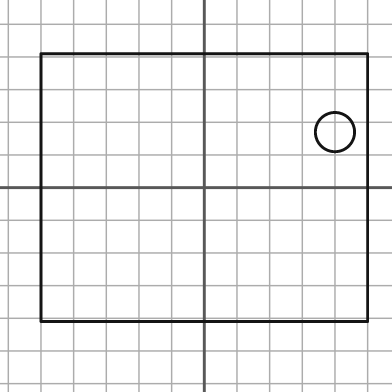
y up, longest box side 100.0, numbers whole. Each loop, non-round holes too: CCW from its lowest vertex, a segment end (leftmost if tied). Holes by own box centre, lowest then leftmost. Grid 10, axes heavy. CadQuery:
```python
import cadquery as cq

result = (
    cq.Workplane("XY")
    .moveTo(-50.0, -41.0)
    .lineTo(50.0, -41.0)
    .lineTo(50.0, 41.0)
    .lineTo(-50.0, 41.0)
    .close()
    .moveTo(40.0, 17.0)
    .circle(6.0)
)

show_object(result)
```